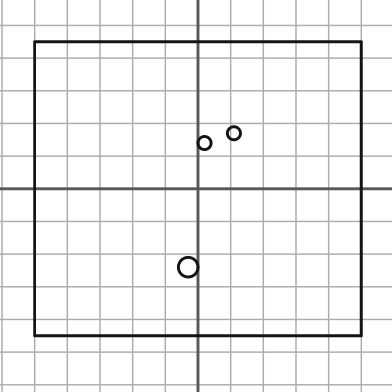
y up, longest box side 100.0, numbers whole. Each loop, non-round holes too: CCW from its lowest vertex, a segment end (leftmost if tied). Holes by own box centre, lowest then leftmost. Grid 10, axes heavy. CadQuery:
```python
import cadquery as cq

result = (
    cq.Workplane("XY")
    .moveTo(-50.0, -45.0)
    .lineTo(50.0, -45.0)
    .lineTo(50.0, 45.0)
    .lineTo(-50.0, 45.0)
    .close()
    .moveTo(-3.0, -24.0)
    .circle(3.0)
    .moveTo(2.0, 14.0)
    .circle(2.0)
    .moveTo(11.0, 17.0)
    .circle(2.0)
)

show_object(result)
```